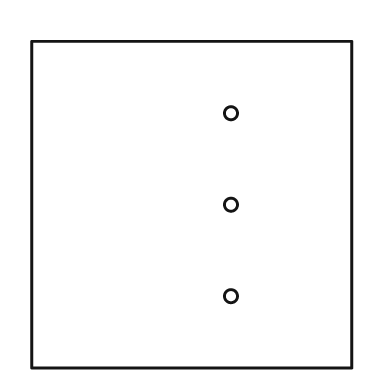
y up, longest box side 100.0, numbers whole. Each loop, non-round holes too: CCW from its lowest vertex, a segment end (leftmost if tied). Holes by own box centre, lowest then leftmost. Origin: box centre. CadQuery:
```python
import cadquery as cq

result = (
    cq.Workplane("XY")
    .moveTo(-49.0, -50.0)
    .lineTo(49.0, -50.0)
    .lineTo(49.0, 50.0)
    .lineTo(-49.0, 50.0)
    .close()
    .moveTo(12.0, -28.0)
    .circle(2.0)
    .moveTo(12.0, 0.0)
    .circle(2.0)
    .moveTo(12.0, 28.0)
    .circle(2.0)
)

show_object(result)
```